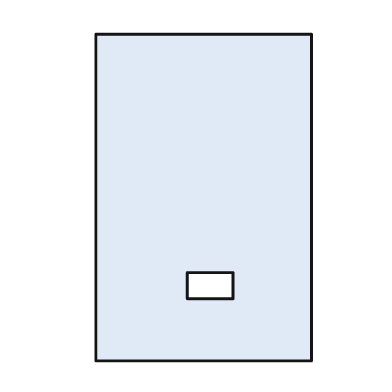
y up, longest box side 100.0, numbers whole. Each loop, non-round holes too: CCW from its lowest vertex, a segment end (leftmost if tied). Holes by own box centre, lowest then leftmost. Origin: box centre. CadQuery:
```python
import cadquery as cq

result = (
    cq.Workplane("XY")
    .moveTo(-33.0, -50.0)
    .lineTo(33.0, -50.0)
    .lineTo(33.0, 50.0)
    .lineTo(-33.0, 50.0)
    .close()
    .moveTo(-5.0, -31.0)
    .lineTo(9.0, -31.0)
    .lineTo(9.0, -23.0)
    .lineTo(-5.0, -23.0)
    .close()
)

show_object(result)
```